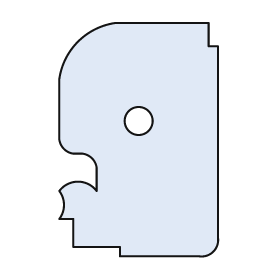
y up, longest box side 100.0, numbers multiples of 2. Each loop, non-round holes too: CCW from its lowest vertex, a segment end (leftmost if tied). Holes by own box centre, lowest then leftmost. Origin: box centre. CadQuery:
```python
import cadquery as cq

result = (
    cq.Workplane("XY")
    .moveTo(-8.0, -50.0)
    .lineTo(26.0, -50.0)
    .threePointArc((32.0, -48.0), (34.0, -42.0))
    .lineTo(34.0, 40.0)
    .lineTo(30.0, 40.0)
    .lineTo(30.0, 50.0)
    .lineTo(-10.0, 50.0)
    .threePointArc((-26.0, 42.0), (-34.0, 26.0))
    .lineTo(-34.0, 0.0)
    .threePointArc((-32.0, -4.0), (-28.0, -6.0))
    .lineTo(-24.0, -6.0)
    .threePointArc((-20.0, -8.0), (-18.0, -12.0))
    .lineTo(-18.0, -22.0)
    .threePointArc((-26.0, -18.0), (-34.0, -22.0))
    .threePointArc((-32.0, -28.0), (-34.0, -34.0))
    .lineTo(-28.0, -34.0)
    .lineTo(-28.0, -46.0)
    .lineTo(-8.0, -46.0)
    .close()
    .moveTo(0.0, 8.0)
    .circle(6.0)
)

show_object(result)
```